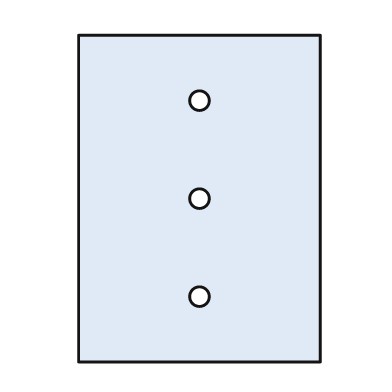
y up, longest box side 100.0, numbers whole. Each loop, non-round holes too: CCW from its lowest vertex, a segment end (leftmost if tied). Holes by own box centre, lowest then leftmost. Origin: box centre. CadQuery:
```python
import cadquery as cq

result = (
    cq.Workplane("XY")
    .moveTo(-37.0, -50.0)
    .lineTo(37.0, -50.0)
    .lineTo(37.0, 50.0)
    .lineTo(-37.0, 50.0)
    .close()
    .moveTo(0.0, -30.0)
    .circle(3.0)
    .moveTo(0.0, 0.0)
    .circle(3.0)
    .moveTo(0.0, 30.0)
    .circle(3.0)
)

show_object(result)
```